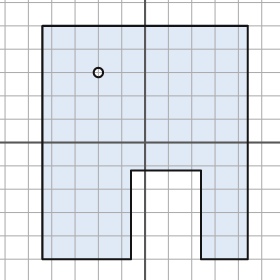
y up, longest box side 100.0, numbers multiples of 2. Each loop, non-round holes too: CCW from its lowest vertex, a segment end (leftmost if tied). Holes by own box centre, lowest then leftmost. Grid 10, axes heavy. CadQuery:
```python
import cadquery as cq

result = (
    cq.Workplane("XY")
    .moveTo(-44.0, -50.0)
    .lineTo(-6.0, -50.0)
    .lineTo(-6.0, -12.0)
    .lineTo(24.0, -12.0)
    .lineTo(24.0, -50.0)
    .lineTo(44.0, -50.0)
    .lineTo(44.0, 50.0)
    .lineTo(-44.0, 50.0)
    .close()
    .moveTo(-20.0, 30.0)
    .circle(2.0)
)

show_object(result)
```